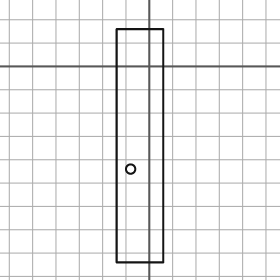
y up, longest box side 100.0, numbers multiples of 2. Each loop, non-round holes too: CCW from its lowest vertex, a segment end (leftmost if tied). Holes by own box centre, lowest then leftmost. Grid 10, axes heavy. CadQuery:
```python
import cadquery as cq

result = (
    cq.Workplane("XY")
    .moveTo(-14.0, -84.0)
    .lineTo(6.0, -84.0)
    .lineTo(6.0, 16.0)
    .lineTo(-14.0, 16.0)
    .close()
    .moveTo(-8.0, -44.0)
    .circle(2.0)
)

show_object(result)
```